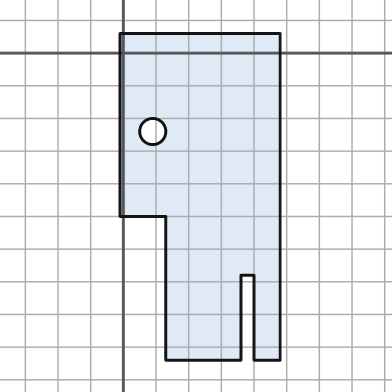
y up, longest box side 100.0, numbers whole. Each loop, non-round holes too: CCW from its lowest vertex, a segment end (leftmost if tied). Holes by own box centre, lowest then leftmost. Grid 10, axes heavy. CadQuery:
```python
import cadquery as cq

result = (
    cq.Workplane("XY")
    .moveTo(13.0, -94.0)
    .lineTo(36.0, -94.0)
    .lineTo(36.0, -68.0)
    .lineTo(40.0, -68.0)
    .lineTo(40.0, -94.0)
    .lineTo(48.0, -94.0)
    .lineTo(48.0, 6.0)
    .lineTo(-1.0, 6.0)
    .lineTo(-1.0, -50.0)
    .lineTo(13.0, -50.0)
    .close()
    .moveTo(9.0, -24.0)
    .circle(4.0)
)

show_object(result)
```